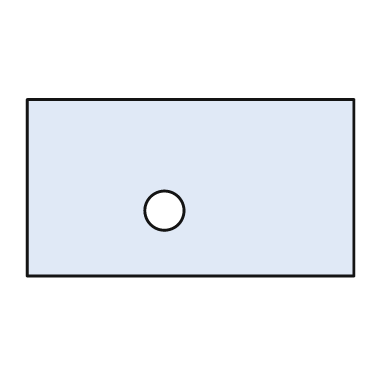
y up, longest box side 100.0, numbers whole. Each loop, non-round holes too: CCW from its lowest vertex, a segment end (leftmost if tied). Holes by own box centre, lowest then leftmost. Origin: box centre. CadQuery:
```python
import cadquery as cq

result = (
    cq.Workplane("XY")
    .moveTo(-50.0, -27.0)
    .lineTo(50.0, -27.0)
    .lineTo(50.0, 27.0)
    .lineTo(-50.0, 27.0)
    .close()
    .moveTo(-8.0, -7.0)
    .circle(6.0)
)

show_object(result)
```